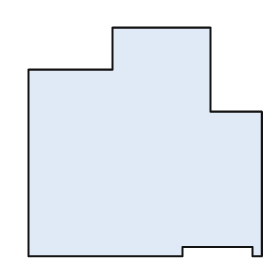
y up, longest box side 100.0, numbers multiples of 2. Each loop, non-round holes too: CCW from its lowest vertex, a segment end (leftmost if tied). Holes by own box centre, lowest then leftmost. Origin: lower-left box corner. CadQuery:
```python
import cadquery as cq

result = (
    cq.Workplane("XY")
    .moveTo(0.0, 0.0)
    .lineTo(66.0, 0.0)
    .lineTo(66.0, 4.0)
    .lineTo(96.0, 4.0)
    .lineTo(96.0, 0.0)
    .lineTo(100.0, 0.0)
    .lineTo(100.0, 62.0)
    .lineTo(78.0, 62.0)
    .lineTo(78.0, 98.0)
    .lineTo(36.0, 98.0)
    .lineTo(36.0, 80.0)
    .lineTo(0.0, 80.0)
    .close()
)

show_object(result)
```